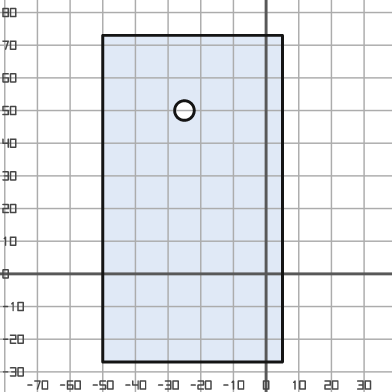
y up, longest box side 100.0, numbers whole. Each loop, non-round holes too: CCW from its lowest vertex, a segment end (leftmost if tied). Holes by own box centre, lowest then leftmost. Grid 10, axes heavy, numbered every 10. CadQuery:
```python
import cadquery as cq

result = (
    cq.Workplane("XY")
    .moveTo(-50.0, -27.0)
    .lineTo(5.0, -27.0)
    .lineTo(5.0, 73.0)
    .lineTo(-50.0, 73.0)
    .close()
    .moveTo(-25.0, 50.0)
    .circle(3.0)
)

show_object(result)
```